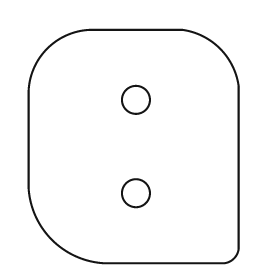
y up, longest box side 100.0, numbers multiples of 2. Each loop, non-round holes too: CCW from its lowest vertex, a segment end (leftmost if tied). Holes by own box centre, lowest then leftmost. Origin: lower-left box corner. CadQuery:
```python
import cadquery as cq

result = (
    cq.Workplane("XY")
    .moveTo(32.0, 0.0)
    .lineTo(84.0, 0.0)
    .threePointArc((88.0, 2.0), (90.0, 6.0))
    .lineTo(90.0, 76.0)
    .threePointArc((82.0, 92.0), (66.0, 100.0))
    .lineTo(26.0, 100.0)
    .threePointArc((8.0, 92.0), (0.0, 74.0))
    .lineTo(0.0, 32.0)
    .threePointArc((10.0, 10.0), (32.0, 0.0))
    .close()
    .moveTo(46.0, 30.0)
    .circle(6.0)
    .moveTo(46.0, 70.0)
    .circle(6.0)
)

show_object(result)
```